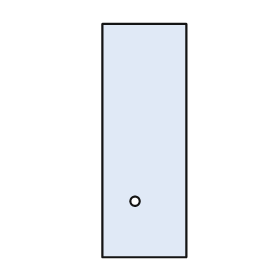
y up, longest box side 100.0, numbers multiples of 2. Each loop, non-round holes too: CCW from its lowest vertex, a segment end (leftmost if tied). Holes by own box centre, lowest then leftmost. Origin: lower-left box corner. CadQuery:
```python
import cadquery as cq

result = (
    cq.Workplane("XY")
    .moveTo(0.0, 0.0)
    .lineTo(36.0, 0.0)
    .lineTo(36.0, 100.0)
    .lineTo(0.0, 100.0)
    .close()
    .moveTo(14.0, 24.0)
    .circle(2.0)
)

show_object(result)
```